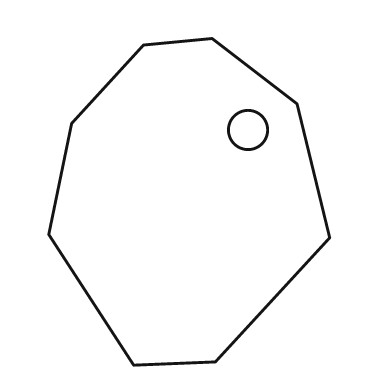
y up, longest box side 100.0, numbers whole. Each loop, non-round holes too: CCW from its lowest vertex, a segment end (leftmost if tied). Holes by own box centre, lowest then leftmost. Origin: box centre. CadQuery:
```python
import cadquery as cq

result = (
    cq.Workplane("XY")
    .moveTo(-17.0, -50.0)
    .lineTo(8.0, -49.0)
    .lineTo(43.0, -11.0)
    .lineTo(33.0, 30.0)
    .lineTo(7.0, 50.0)
    .lineTo(-14.0, 48.0)
    .lineTo(-36.0, 24.0)
    .lineTo(-43.0, -10.0)
    .close()
    .moveTo(18.0, 22.0)
    .circle(6.0)
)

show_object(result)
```